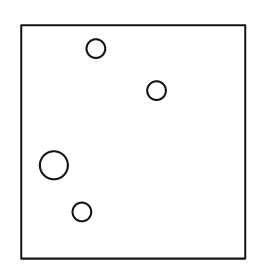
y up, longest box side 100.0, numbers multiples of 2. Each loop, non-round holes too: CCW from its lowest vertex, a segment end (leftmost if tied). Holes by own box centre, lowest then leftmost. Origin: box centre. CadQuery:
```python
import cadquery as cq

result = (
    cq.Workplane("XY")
    .moveTo(-48.0, -50.0)
    .lineTo(48.0, -50.0)
    .lineTo(48.0, 50.0)
    .lineTo(-48.0, 50.0)
    .close()
    .moveTo(-22.0, -30.0)
    .circle(4.0)
    .moveTo(-34.0, -10.0)
    .circle(6.0)
    .moveTo(10.0, 22.0)
    .circle(4.0)
    .moveTo(-16.0, 40.0)
    .circle(4.0)
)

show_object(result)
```